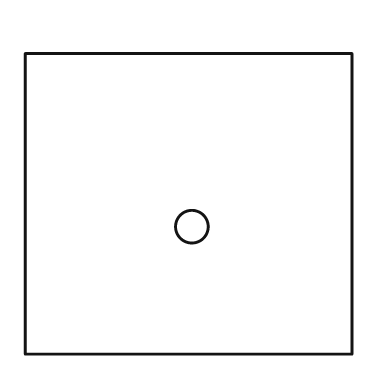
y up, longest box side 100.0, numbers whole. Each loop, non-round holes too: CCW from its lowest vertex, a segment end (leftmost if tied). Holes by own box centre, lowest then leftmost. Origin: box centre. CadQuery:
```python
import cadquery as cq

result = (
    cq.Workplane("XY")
    .moveTo(-50.0, -46.0)
    .lineTo(50.0, -46.0)
    .lineTo(50.0, 46.0)
    .lineTo(-50.0, 46.0)
    .close()
    .moveTo(1.0, -7.0)
    .circle(5.0)
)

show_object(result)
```